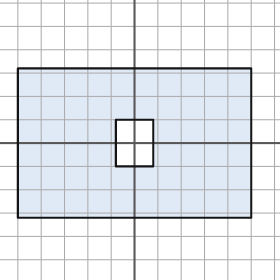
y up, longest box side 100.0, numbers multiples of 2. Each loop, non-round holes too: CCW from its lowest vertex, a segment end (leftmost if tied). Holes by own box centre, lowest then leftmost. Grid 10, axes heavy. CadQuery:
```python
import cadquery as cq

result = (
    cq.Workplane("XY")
    .moveTo(-50.0, -32.0)
    .lineTo(50.0, -32.0)
    .lineTo(50.0, 32.0)
    .lineTo(-50.0, 32.0)
    .close()
    .moveTo(-8.0, -10.0)
    .lineTo(8.0, -10.0)
    .lineTo(8.0, 10.0)
    .lineTo(-8.0, 10.0)
    .close()
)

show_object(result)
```